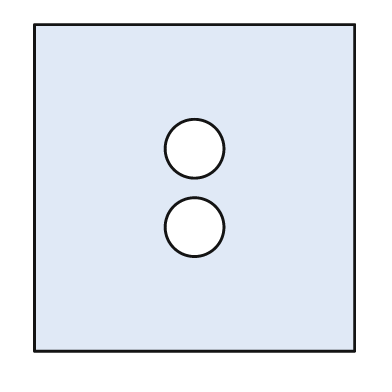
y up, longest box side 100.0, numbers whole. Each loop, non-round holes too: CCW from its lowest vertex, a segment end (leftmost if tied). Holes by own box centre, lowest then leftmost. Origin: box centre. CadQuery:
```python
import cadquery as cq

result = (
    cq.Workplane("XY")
    .moveTo(-49.0, -50.0)
    .lineTo(49.0, -50.0)
    .lineTo(49.0, 50.0)
    .lineTo(-49.0, 50.0)
    .close()
    .moveTo(0.0, -12.0)
    .circle(9.0)
    .moveTo(0.0, 12.0)
    .circle(9.0)
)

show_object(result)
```